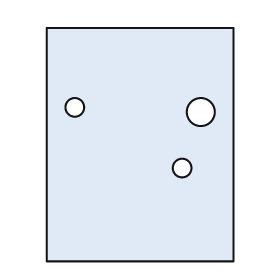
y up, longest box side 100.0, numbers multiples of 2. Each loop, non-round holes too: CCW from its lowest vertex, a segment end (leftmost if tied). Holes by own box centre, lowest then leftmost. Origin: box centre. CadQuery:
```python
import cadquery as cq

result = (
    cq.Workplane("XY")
    .moveTo(-40.0, -50.0)
    .lineTo(40.0, -50.0)
    .lineTo(40.0, 50.0)
    .lineTo(-40.0, 50.0)
    .close()
    .moveTo(18.0, -10.0)
    .circle(4.0)
    .moveTo(26.0, 14.0)
    .circle(6.0)
    .moveTo(-28.0, 16.0)
    .circle(4.0)
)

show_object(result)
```